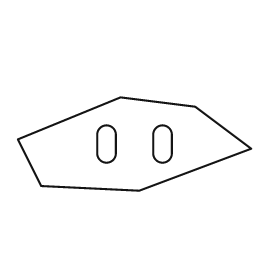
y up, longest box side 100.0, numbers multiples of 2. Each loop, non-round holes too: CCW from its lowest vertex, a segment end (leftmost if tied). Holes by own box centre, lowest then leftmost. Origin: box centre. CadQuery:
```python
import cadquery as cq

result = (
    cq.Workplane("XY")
    .moveTo(2.0, -20.0)
    .lineTo(50.0, -2.0)
    .lineTo(26.0, 16.0)
    .lineTo(-6.0, 20.0)
    .lineTo(-50.0, 2.0)
    .lineTo(-40.0, -18.0)
    .close()
    .moveTo(-16.0, -4.0)
    .threePointArc((-12.0, -8.0), (-8.0, -4.0))
    .lineTo(-8.0, 4.0)
    .threePointArc((-12.0, 8.0), (-16.0, 4.0))
    .close()
    .moveTo(8.0, -4.0)
    .threePointArc((12.0, -8.0), (16.0, -4.0))
    .lineTo(16.0, 4.0)
    .threePointArc((12.0, 8.0), (8.0, 4.0))
    .close()
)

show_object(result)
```